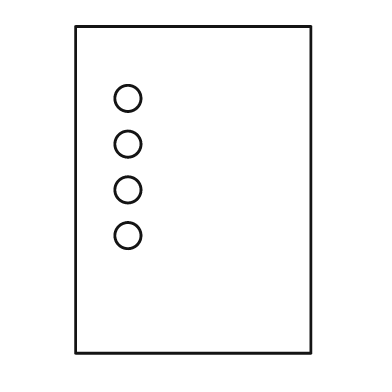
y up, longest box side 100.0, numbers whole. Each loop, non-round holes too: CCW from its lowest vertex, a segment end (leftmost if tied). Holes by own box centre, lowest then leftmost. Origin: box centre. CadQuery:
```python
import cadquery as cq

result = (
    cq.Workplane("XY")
    .moveTo(-36.0, -50.0)
    .lineTo(36.0, -50.0)
    .lineTo(36.0, 50.0)
    .lineTo(-36.0, 50.0)
    .close()
    .moveTo(-20.0, -14.0)
    .circle(4.0)
    .moveTo(-20.0, 0.0)
    .circle(4.0)
    .moveTo(-20.0, 14.0)
    .circle(4.0)
    .moveTo(-20.0, 28.0)
    .circle(4.0)
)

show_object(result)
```